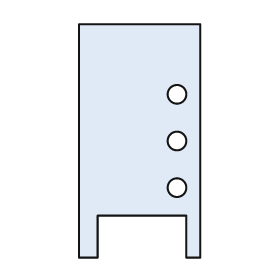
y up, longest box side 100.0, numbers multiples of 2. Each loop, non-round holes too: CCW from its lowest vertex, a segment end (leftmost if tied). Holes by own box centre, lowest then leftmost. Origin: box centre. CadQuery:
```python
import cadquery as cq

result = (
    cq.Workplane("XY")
    .moveTo(-26.0, -50.0)
    .lineTo(-18.0, -50.0)
    .lineTo(-18.0, -32.0)
    .lineTo(20.0, -32.0)
    .lineTo(20.0, -50.0)
    .lineTo(26.0, -50.0)
    .lineTo(26.0, 50.0)
    .lineTo(-26.0, 50.0)
    .close()
    .moveTo(16.0, -20.0)
    .circle(4.0)
    .moveTo(16.0, 0.0)
    .circle(4.0)
    .moveTo(16.0, 20.0)
    .circle(4.0)
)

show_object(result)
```